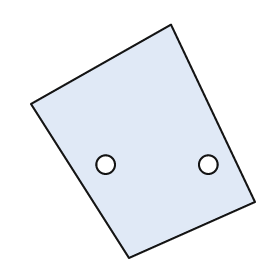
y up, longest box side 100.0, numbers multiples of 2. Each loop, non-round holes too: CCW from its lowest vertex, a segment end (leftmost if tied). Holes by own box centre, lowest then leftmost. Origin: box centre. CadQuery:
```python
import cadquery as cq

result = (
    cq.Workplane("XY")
    .moveTo(-6.0, -50.0)
    .lineTo(48.0, -26.0)
    .lineTo(12.0, 50.0)
    .lineTo(-48.0, 16.0)
    .close()
    .moveTo(-16.0, -10.0)
    .circle(4.0)
    .moveTo(28.0, -10.0)
    .circle(4.0)
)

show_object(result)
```